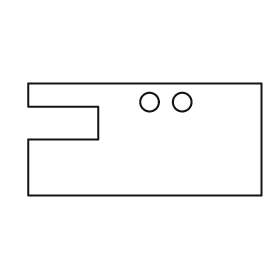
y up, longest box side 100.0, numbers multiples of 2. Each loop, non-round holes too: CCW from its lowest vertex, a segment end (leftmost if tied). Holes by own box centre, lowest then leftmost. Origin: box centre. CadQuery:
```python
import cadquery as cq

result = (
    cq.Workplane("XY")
    .moveTo(-50.0, -24.0)
    .lineTo(50.0, -24.0)
    .lineTo(50.0, 24.0)
    .lineTo(-50.0, 24.0)
    .lineTo(-50.0, 14.0)
    .lineTo(-20.0, 14.0)
    .lineTo(-20.0, 0.0)
    .lineTo(-50.0, 0.0)
    .close()
    .moveTo(2.0, 16.0)
    .circle(4.0)
    .moveTo(16.0, 16.0)
    .circle(4.0)
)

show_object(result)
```